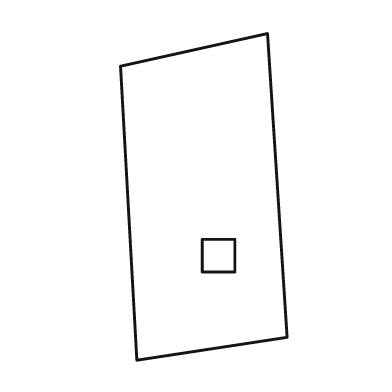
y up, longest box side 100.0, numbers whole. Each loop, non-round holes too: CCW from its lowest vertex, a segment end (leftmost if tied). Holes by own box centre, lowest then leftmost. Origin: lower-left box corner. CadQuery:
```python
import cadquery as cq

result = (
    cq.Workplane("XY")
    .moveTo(5.0, 0.0)
    .lineTo(51.0, 7.0)
    .lineTo(45.0, 100.0)
    .lineTo(0.0, 90.0)
    .close()
    .moveTo(25.0, 27.0)
    .lineTo(35.0, 27.0)
    .lineTo(35.0, 37.0)
    .lineTo(25.0, 37.0)
    .close()
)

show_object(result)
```